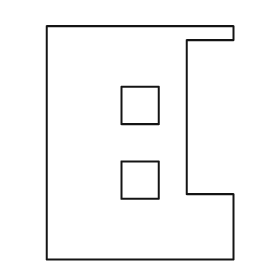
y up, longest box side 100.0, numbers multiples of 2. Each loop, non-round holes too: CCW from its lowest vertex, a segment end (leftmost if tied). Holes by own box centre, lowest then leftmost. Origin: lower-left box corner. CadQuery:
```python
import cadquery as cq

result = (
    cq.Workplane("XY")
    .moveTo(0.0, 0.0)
    .lineTo(80.0, 0.0)
    .lineTo(80.0, 28.0)
    .lineTo(60.0, 28.0)
    .lineTo(60.0, 94.0)
    .lineTo(80.0, 94.0)
    .lineTo(80.0, 100.0)
    .lineTo(0.0, 100.0)
    .close()
    .moveTo(32.0, 26.0)
    .lineTo(48.0, 26.0)
    .lineTo(48.0, 42.0)
    .lineTo(32.0, 42.0)
    .close()
    .moveTo(32.0, 58.0)
    .lineTo(48.0, 58.0)
    .lineTo(48.0, 74.0)
    .lineTo(32.0, 74.0)
    .close()
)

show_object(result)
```